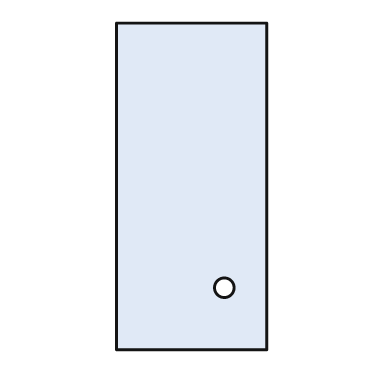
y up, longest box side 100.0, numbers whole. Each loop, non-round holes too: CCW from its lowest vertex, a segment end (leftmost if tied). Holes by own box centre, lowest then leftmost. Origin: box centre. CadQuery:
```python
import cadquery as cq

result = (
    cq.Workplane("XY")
    .moveTo(-23.0, -50.0)
    .lineTo(23.0, -50.0)
    .lineTo(23.0, 50.0)
    .lineTo(-23.0, 50.0)
    .close()
    .moveTo(10.0, -31.0)
    .circle(3.0)
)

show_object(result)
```